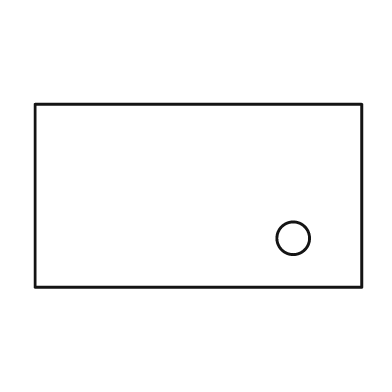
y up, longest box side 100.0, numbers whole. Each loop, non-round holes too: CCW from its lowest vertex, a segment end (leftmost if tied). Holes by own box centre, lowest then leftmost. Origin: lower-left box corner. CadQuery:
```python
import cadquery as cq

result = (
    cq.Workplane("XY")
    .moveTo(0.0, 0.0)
    .lineTo(100.0, 0.0)
    .lineTo(100.0, 56.0)
    .lineTo(0.0, 56.0)
    .close()
    .moveTo(79.0, 15.0)
    .circle(5.0)
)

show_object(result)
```